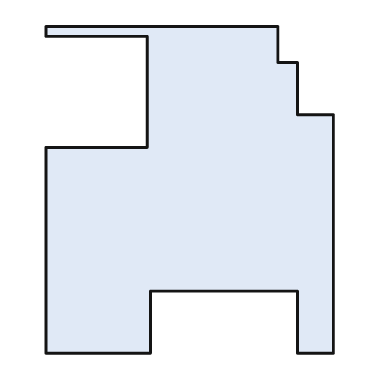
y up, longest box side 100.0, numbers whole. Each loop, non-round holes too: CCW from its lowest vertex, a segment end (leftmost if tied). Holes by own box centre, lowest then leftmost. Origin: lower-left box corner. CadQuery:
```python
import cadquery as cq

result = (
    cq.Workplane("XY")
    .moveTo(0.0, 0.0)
    .lineTo(32.0, 0.0)
    .lineTo(32.0, 19.0)
    .lineTo(77.0, 19.0)
    .lineTo(77.0, 0.0)
    .lineTo(88.0, 0.0)
    .lineTo(88.0, 73.0)
    .lineTo(77.0, 73.0)
    .lineTo(77.0, 89.0)
    .lineTo(71.0, 89.0)
    .lineTo(71.0, 100.0)
    .lineTo(0.0, 100.0)
    .lineTo(0.0, 97.0)
    .lineTo(31.0, 97.0)
    .lineTo(31.0, 63.0)
    .lineTo(0.0, 63.0)
    .close()
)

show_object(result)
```